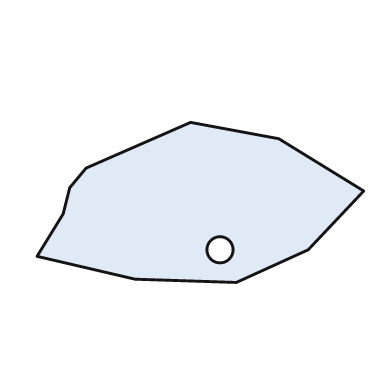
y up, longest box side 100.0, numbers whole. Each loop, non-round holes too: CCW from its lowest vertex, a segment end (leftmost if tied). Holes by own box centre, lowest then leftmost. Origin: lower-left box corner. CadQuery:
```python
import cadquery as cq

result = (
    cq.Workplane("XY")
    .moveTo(61.0, 0.0)
    .lineTo(83.0, 10.0)
    .lineTo(100.0, 28.0)
    .lineTo(74.0, 44.0)
    .lineTo(47.0, 49.0)
    .lineTo(15.0, 35.0)
    .lineTo(10.0, 29.0)
    .lineTo(8.0, 21.0)
    .lineTo(0.0, 8.0)
    .lineTo(30.0, 1.0)
    .close()
    .moveTo(56.0, 10.0)
    .circle(4.0)
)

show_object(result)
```